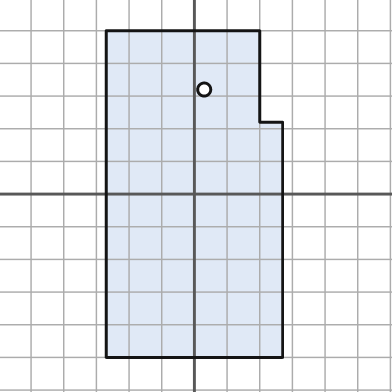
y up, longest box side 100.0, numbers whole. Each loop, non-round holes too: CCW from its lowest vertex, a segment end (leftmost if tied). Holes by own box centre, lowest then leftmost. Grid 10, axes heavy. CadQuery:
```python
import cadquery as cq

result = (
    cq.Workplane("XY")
    .moveTo(-27.0, -50.0)
    .lineTo(27.0, -50.0)
    .lineTo(27.0, 22.0)
    .lineTo(20.0, 22.0)
    .lineTo(20.0, 50.0)
    .lineTo(-27.0, 50.0)
    .close()
    .moveTo(3.0, 32.0)
    .circle(2.0)
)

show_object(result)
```